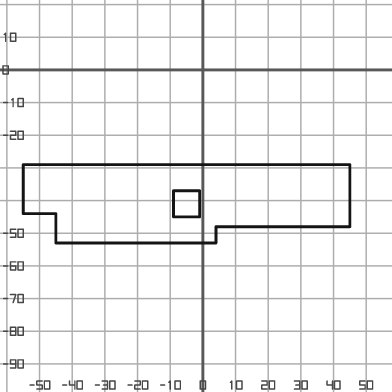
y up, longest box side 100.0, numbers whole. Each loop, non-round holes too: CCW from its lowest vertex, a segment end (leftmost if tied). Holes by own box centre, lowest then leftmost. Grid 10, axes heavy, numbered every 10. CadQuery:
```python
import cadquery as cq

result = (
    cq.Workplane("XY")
    .moveTo(-45.0, -53.0)
    .lineTo(4.0, -53.0)
    .lineTo(4.0, -48.0)
    .lineTo(45.0, -48.0)
    .lineTo(45.0, -29.0)
    .lineTo(-55.0, -29.0)
    .lineTo(-55.0, -44.0)
    .lineTo(-45.0, -44.0)
    .close()
    .moveTo(-9.0, -45.0)
    .lineTo(-1.0, -45.0)
    .lineTo(-1.0, -37.0)
    .lineTo(-9.0, -37.0)
    .close()
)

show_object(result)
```